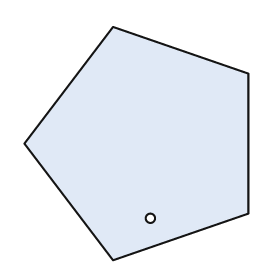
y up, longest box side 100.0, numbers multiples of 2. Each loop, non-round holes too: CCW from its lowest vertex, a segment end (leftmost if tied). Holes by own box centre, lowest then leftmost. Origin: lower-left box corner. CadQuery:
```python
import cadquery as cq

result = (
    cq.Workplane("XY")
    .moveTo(38.0, 0.0)
    .lineTo(96.0, 20.0)
    .lineTo(96.0, 80.0)
    .lineTo(38.0, 100.0)
    .lineTo(0.0, 50.0)
    .close()
    .moveTo(54.0, 18.0)
    .circle(2.0)
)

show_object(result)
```